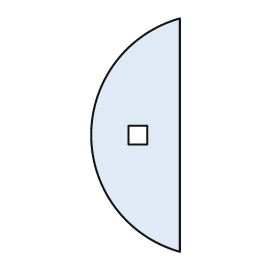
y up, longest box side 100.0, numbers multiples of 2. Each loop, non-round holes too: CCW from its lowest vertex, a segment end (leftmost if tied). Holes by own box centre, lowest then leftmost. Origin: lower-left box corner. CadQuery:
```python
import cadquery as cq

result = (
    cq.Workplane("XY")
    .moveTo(38.0, 0.0)
    .lineTo(38.0, 100.0)
    .threePointArc((0.0, 50.0), (38.0, 0.0))
    .close()
    .moveTo(16.0, 46.0)
    .lineTo(24.0, 46.0)
    .lineTo(24.0, 54.0)
    .lineTo(16.0, 54.0)
    .close()
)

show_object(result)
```